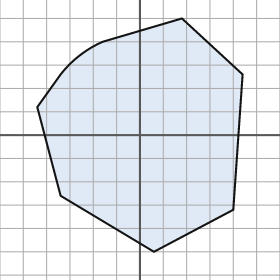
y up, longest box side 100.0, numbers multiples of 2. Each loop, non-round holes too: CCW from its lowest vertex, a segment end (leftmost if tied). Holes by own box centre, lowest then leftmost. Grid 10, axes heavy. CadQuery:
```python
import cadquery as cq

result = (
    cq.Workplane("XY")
    .moveTo(6.0, -50.0)
    .lineTo(40.0, -32.0)
    .lineTo(44.0, 26.0)
    .lineTo(18.0, 50.0)
    .lineTo(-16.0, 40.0)
    .threePointArc((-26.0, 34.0), (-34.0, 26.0))
    .lineTo(-44.0, 12.0)
    .lineTo(-34.0, -26.0)
    .close()
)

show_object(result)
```